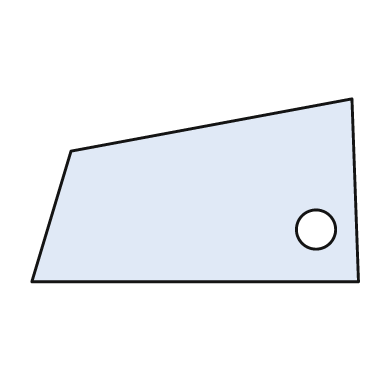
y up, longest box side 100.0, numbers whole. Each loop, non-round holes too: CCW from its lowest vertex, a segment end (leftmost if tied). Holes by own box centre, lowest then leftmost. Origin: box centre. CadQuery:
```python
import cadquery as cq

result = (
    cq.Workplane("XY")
    .moveTo(-50.0, -28.0)
    .lineTo(50.0, -28.0)
    .lineTo(48.0, 28.0)
    .lineTo(-38.0, 12.0)
    .close()
    .moveTo(37.0, -12.0)
    .circle(6.0)
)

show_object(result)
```